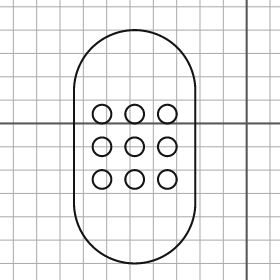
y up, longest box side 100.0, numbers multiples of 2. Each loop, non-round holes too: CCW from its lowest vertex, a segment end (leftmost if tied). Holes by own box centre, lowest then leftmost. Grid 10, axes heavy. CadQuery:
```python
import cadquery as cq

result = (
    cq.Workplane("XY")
    .moveTo(-74.0, -34.0)
    .threePointArc((-48.0, -60.0), (-22.0, -34.0))
    .lineTo(-22.0, 14.0)
    .threePointArc((-48.0, 40.0), (-74.0, 14.0))
    .close()
    .moveTo(-62.0, -24.0)
    .circle(4.0)
    .moveTo(-48.0, -24.0)
    .circle(4.0)
    .moveTo(-34.0, -24.0)
    .circle(4.0)
    .moveTo(-62.0, -10.0)
    .circle(4.0)
    .moveTo(-48.0, -10.0)
    .circle(4.0)
    .moveTo(-34.0, -10.0)
    .circle(4.0)
    .moveTo(-62.0, 4.0)
    .circle(4.0)
    .moveTo(-48.0, 4.0)
    .circle(4.0)
    .moveTo(-34.0, 4.0)
    .circle(4.0)
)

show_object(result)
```